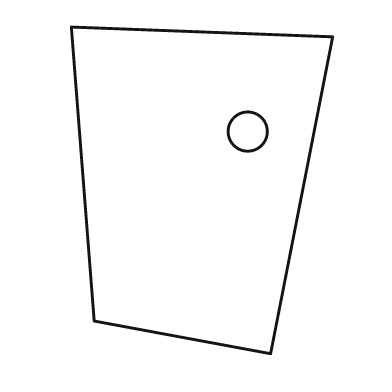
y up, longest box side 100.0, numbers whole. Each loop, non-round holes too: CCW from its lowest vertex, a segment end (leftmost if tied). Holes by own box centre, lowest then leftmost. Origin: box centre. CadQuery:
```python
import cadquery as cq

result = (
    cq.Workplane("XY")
    .moveTo(21.0, -50.0)
    .lineTo(40.0, 47.0)
    .lineTo(-40.0, 50.0)
    .lineTo(-33.0, -40.0)
    .close()
    .moveTo(14.0, 18.0)
    .circle(6.0)
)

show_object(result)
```